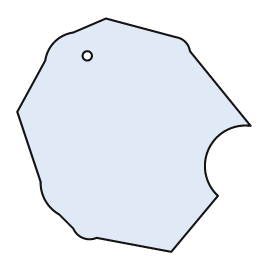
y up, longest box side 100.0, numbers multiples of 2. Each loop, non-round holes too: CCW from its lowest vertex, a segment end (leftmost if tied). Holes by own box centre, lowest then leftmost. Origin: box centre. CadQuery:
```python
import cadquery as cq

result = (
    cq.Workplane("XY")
    .moveTo(16.0, -50.0)
    .lineTo(36.0, -26.0)
    .threePointArc((32.0, -6.0), (50.0, 4.0))
    .lineTo(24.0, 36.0)
    .threePointArc((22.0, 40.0), (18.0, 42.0))
    .lineTo(-12.0, 50.0)
    .lineTo(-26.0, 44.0)
    .threePointArc((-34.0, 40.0), (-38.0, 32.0))
    .lineTo(-50.0, 10.0)
    .lineTo(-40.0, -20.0)
    .threePointArc((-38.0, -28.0), (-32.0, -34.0))
    .lineTo(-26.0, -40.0)
    .threePointArc((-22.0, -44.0), (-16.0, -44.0))
    .close()
    .moveTo(-20.0, 34.0)
    .circle(2.0)
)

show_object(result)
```